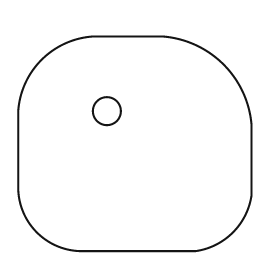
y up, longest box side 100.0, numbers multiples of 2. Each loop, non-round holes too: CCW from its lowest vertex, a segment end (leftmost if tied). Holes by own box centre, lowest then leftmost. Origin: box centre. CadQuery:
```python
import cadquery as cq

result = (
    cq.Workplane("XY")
    .moveTo(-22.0, -46.0)
    .lineTo(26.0, -46.0)
    .threePointArc((42.0, -38.0), (50.0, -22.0))
    .lineTo(50.0, 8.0)
    .threePointArc((38.0, 34.0), (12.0, 46.0))
    .lineTo(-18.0, 46.0)
    .threePointArc((-40.0, 36.0), (-50.0, 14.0))
    .lineTo(-50.0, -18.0)
    .threePointArc((-42.0, -38.0), (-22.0, -46.0))
    .close()
    .moveTo(-12.0, 14.0)
    .circle(6.0)
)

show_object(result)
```